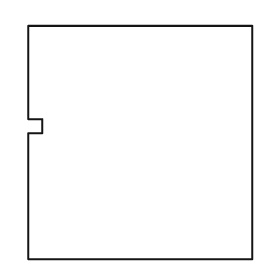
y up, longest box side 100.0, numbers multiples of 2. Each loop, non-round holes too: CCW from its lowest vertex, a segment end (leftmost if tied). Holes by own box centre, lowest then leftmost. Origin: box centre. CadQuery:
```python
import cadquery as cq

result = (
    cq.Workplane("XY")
    .moveTo(-48.0, -50.0)
    .lineTo(48.0, -50.0)
    .lineTo(48.0, 50.0)
    .lineTo(-48.0, 50.0)
    .lineTo(-48.0, 10.0)
    .lineTo(-42.0, 10.0)
    .lineTo(-42.0, 4.0)
    .lineTo(-48.0, 4.0)
    .close()
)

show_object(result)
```